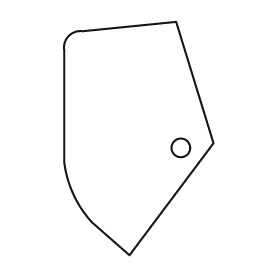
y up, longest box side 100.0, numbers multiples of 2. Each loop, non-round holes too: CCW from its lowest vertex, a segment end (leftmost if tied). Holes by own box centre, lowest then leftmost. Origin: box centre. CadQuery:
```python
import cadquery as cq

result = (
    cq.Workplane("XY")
    .moveTo(-4.0, -50.0)
    .lineTo(32.0, -2.0)
    .lineTo(16.0, 50.0)
    .lineTo(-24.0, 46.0)
    .threePointArc((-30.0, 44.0), (-32.0, 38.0))
    .lineTo(-32.0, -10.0)
    .threePointArc((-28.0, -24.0), (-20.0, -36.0))
    .close()
    .moveTo(18.0, -4.0)
    .circle(4.0)
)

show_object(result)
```